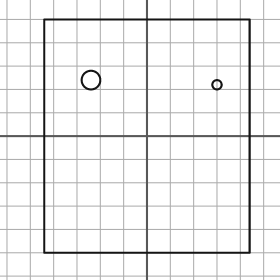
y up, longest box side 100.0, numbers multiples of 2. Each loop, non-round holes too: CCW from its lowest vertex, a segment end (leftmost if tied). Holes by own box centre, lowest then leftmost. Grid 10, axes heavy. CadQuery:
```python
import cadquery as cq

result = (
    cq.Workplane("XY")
    .moveTo(-44.0, -50.0)
    .lineTo(44.0, -50.0)
    .lineTo(44.0, 50.0)
    .lineTo(-44.0, 50.0)
    .close()
    .moveTo(30.0, 22.0)
    .circle(2.0)
    .moveTo(-24.0, 24.0)
    .circle(4.0)
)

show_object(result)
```